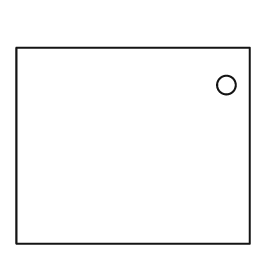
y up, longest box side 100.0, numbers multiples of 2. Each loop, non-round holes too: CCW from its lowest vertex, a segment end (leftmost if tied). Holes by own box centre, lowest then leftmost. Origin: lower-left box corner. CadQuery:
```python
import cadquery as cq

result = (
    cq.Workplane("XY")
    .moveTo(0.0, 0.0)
    .lineTo(100.0, 0.0)
    .lineTo(100.0, 84.0)
    .lineTo(0.0, 84.0)
    .close()
    .moveTo(90.0, 68.0)
    .circle(4.0)
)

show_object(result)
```